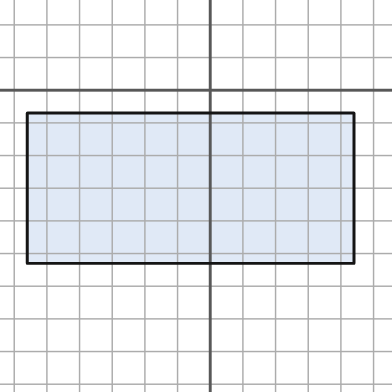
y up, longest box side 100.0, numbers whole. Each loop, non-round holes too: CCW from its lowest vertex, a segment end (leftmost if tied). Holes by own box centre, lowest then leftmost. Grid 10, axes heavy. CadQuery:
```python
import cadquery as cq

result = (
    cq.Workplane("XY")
    .moveTo(-56.0, -53.0)
    .lineTo(44.0, -53.0)
    .lineTo(44.0, -7.0)
    .lineTo(-56.0, -7.0)
    .close()
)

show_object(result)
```